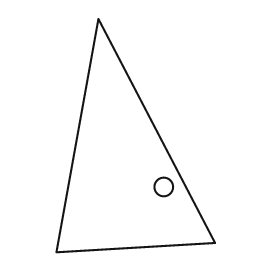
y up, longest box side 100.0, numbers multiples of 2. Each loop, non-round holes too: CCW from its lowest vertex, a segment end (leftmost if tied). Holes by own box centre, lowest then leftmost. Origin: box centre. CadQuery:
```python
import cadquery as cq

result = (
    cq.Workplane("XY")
    .moveTo(-34.0, -50.0)
    .lineTo(34.0, -46.0)
    .lineTo(-16.0, 50.0)
    .close()
    .moveTo(12.0, -22.0)
    .circle(4.0)
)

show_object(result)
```